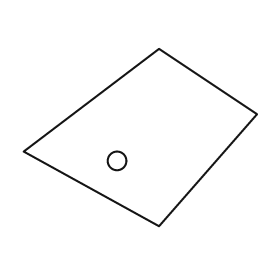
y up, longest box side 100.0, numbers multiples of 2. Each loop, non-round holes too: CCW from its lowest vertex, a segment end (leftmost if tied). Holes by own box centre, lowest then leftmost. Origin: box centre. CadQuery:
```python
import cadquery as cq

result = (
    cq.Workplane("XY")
    .moveTo(8.0, -38.0)
    .lineTo(50.0, 10.0)
    .lineTo(8.0, 38.0)
    .lineTo(-50.0, -6.0)
    .close()
    .moveTo(-10.0, -10.0)
    .circle(4.0)
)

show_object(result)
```